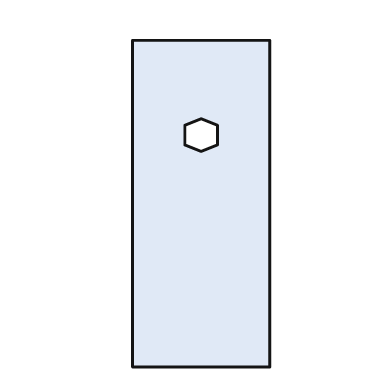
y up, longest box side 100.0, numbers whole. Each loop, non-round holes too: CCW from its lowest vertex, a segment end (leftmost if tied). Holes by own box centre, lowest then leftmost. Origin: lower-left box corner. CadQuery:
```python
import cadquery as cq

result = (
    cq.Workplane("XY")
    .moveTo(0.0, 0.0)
    .lineTo(42.0, 0.0)
    .lineTo(42.0, 100.0)
    .lineTo(0.0, 100.0)
    .close()
    .moveTo(21.0, 66.0)
    .lineTo(26.0, 68.0)
    .lineTo(26.0, 74.0)
    .lineTo(21.0, 76.0)
    .lineTo(16.0, 74.0)
    .lineTo(16.0, 68.0)
    .close()
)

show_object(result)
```